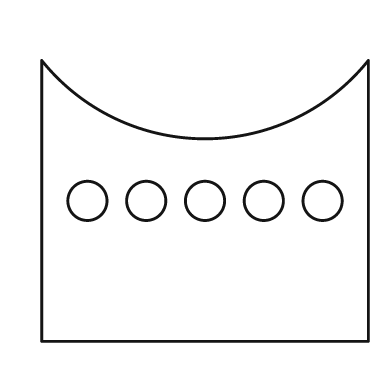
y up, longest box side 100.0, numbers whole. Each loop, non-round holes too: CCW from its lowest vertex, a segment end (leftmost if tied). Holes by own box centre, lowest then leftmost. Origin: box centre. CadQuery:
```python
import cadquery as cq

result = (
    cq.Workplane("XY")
    .moveTo(-50.0, -43.0)
    .lineTo(50.0, -43.0)
    .lineTo(50.0, 43.0)
    .threePointArc((0.0, 19.0), (-50.0, 43.0))
    .close()
    .moveTo(-36.0, 0.0)
    .circle(6.0)
    .moveTo(-18.0, 0.0)
    .circle(6.0)
    .moveTo(0.0, 0.0)
    .circle(6.0)
    .moveTo(18.0, 0.0)
    .circle(6.0)
    .moveTo(36.0, 0.0)
    .circle(6.0)
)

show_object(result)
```